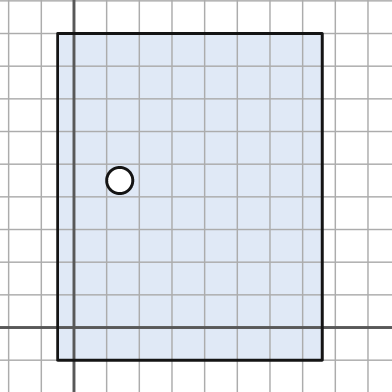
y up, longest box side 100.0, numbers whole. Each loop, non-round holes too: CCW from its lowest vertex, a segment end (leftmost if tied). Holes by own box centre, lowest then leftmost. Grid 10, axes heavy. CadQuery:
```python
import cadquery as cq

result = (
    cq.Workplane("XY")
    .moveTo(-5.0, -10.0)
    .lineTo(76.0, -10.0)
    .lineTo(76.0, 90.0)
    .lineTo(-5.0, 90.0)
    .close()
    .moveTo(14.0, 45.0)
    .circle(4.0)
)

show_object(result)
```